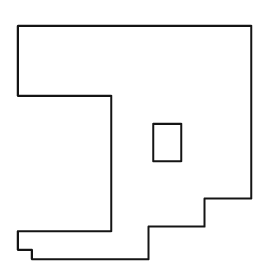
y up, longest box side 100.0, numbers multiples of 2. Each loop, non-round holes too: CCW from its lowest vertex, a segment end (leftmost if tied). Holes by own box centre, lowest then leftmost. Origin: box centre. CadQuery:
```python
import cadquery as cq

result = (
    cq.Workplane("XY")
    .moveTo(-44.0, -50.0)
    .lineTo(6.0, -50.0)
    .lineTo(6.0, -36.0)
    .lineTo(30.0, -36.0)
    .lineTo(30.0, -24.0)
    .lineTo(50.0, -24.0)
    .lineTo(50.0, 50.0)
    .lineTo(-50.0, 50.0)
    .lineTo(-50.0, 20.0)
    .lineTo(-10.0, 20.0)
    .lineTo(-10.0, -38.0)
    .lineTo(-50.0, -38.0)
    .lineTo(-50.0, -46.0)
    .lineTo(-44.0, -46.0)
    .close()
    .moveTo(8.0, -8.0)
    .lineTo(20.0, -8.0)
    .lineTo(20.0, 8.0)
    .lineTo(8.0, 8.0)
    .close()
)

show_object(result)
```